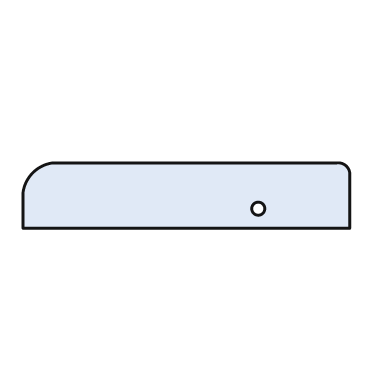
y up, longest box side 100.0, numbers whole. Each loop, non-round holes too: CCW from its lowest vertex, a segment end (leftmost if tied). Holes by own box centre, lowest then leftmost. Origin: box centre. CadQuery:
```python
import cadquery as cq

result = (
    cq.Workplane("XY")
    .moveTo(-50.0, -10.0)
    .lineTo(50.0, -10.0)
    .lineTo(50.0, 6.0)
    .threePointArc((49.0, 9.0), (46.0, 10.0))
    .lineTo(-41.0, 10.0)
    .threePointArc((-47.0, 7.0), (-50.0, 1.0))
    .close()
    .moveTo(22.0, -4.0)
    .circle(2.0)
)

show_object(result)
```